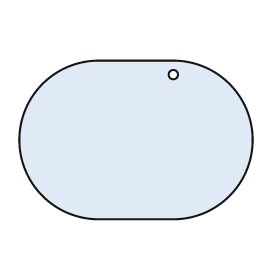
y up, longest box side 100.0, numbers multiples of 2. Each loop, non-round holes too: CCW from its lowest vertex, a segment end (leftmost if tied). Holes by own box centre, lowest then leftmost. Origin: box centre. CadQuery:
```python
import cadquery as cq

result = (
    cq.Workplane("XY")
    .moveTo(-16.0, -34.0)
    .lineTo(16.0, -34.0)
    .threePointArc((50.0, 0.0), (16.0, 34.0))
    .lineTo(-16.0, 34.0)
    .threePointArc((-50.0, 0.0), (-16.0, -34.0))
    .close()
    .moveTo(16.0, 28.0)
    .circle(2.0)
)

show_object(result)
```